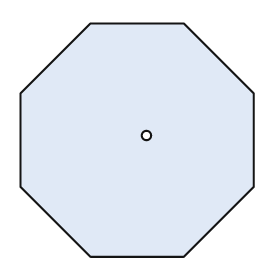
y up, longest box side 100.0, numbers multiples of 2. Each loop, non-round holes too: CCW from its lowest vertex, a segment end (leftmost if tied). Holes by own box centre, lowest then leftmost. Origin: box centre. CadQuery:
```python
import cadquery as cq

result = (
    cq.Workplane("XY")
    .moveTo(-20.0, -50.0)
    .lineTo(20.0, -50.0)
    .lineTo(50.0, -20.0)
    .lineTo(50.0, 20.0)
    .lineTo(20.0, 50.0)
    .lineTo(-20.0, 50.0)
    .lineTo(-50.0, 20.0)
    .lineTo(-50.0, -20.0)
    .close()
    .moveTo(4.0, 2.0)
    .circle(2.0)
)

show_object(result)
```